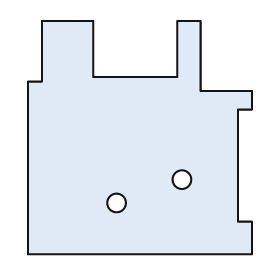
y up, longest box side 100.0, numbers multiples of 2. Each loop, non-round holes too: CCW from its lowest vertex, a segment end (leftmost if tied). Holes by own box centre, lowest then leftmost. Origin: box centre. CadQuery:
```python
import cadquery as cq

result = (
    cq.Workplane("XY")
    .moveTo(-48.0, -50.0)
    .lineTo(48.0, -50.0)
    .lineTo(48.0, -36.0)
    .lineTo(42.0, -36.0)
    .lineTo(42.0, 12.0)
    .lineTo(48.0, 12.0)
    .lineTo(48.0, 20.0)
    .lineTo(26.0, 20.0)
    .lineTo(26.0, 50.0)
    .lineTo(16.0, 50.0)
    .lineTo(16.0, 26.0)
    .lineTo(-20.0, 26.0)
    .lineTo(-20.0, 50.0)
    .lineTo(-42.0, 50.0)
    .lineTo(-42.0, 24.0)
    .lineTo(-48.0, 24.0)
    .close()
    .moveTo(-10.0, -28.0)
    .circle(4.0)
    .moveTo(18.0, -18.0)
    .circle(4.0)
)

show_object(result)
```